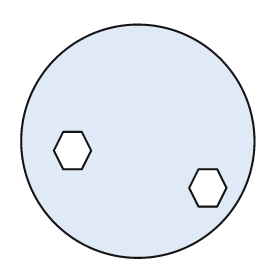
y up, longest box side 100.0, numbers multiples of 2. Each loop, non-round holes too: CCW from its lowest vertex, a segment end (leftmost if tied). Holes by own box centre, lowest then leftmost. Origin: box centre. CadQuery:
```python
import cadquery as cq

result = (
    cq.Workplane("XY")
    .moveTo(0.0, 0.0)
    .circle(50.0)
    .moveTo(26.0, -28.0)
    .lineTo(34.0, -28.0)
    .lineTo(38.0, -20.0)
    .lineTo(34.0, -12.0)
    .lineTo(26.0, -12.0)
    .lineTo(22.0, -20.0)
    .close()
    .moveTo(-32.0, -12.0)
    .lineTo(-24.0, -12.0)
    .lineTo(-20.0, -4.0)
    .lineTo(-24.0, 4.0)
    .lineTo(-32.0, 4.0)
    .lineTo(-36.0, -4.0)
    .close()
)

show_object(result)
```